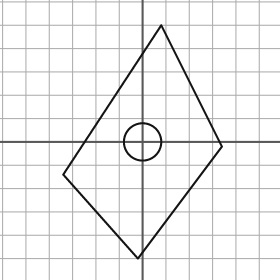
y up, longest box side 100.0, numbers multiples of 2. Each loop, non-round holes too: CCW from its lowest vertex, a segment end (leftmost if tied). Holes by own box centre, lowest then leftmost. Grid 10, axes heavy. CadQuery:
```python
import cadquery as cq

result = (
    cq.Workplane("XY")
    .moveTo(-2.0, -50.0)
    .lineTo(34.0, -2.0)
    .lineTo(8.0, 50.0)
    .lineTo(-34.0, -14.0)
    .close()
    .moveTo(0.0, 0.0)
    .circle(8.0)
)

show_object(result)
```